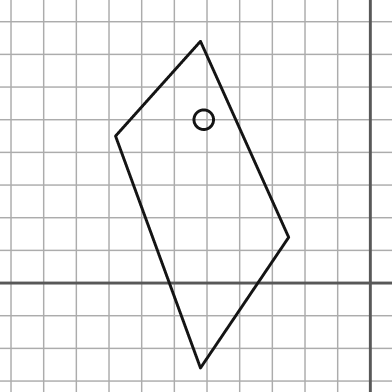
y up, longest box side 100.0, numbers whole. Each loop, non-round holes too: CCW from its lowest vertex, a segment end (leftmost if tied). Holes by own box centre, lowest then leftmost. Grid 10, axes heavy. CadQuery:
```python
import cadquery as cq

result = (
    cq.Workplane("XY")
    .moveTo(-52.0, -26.0)
    .lineTo(-25.0, 14.0)
    .lineTo(-52.0, 74.0)
    .lineTo(-78.0, 45.0)
    .close()
    .moveTo(-51.0, 50.0)
    .circle(3.0)
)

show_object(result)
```